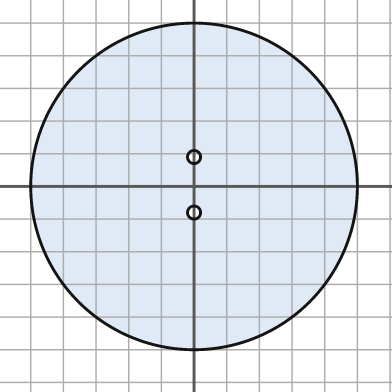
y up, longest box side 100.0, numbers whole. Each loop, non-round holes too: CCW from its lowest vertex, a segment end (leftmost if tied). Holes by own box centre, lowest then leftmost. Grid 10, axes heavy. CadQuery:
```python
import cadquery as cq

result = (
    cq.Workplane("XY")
    .moveTo(0.0, 0.0)
    .circle(50.0)
    .moveTo(0.0, -8.0)
    .circle(2.0)
    .moveTo(0.0, 9.0)
    .circle(2.0)
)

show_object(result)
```